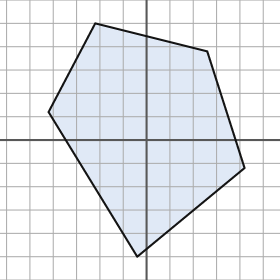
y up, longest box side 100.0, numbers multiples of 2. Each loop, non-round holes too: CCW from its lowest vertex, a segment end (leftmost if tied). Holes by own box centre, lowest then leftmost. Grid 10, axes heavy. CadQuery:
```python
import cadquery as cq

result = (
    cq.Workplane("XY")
    .moveTo(-4.0, -50.0)
    .lineTo(42.0, -12.0)
    .lineTo(26.0, 38.0)
    .lineTo(-22.0, 50.0)
    .lineTo(-42.0, 12.0)
    .close()
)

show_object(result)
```